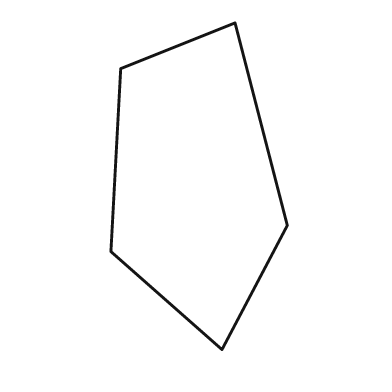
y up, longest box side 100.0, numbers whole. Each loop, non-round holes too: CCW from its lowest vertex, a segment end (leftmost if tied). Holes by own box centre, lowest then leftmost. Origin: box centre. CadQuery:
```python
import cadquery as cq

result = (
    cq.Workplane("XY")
    .moveTo(7.0, -50.0)
    .lineTo(27.0, -12.0)
    .lineTo(11.0, 50.0)
    .lineTo(-24.0, 36.0)
    .lineTo(-27.0, -20.0)
    .close()
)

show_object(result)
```